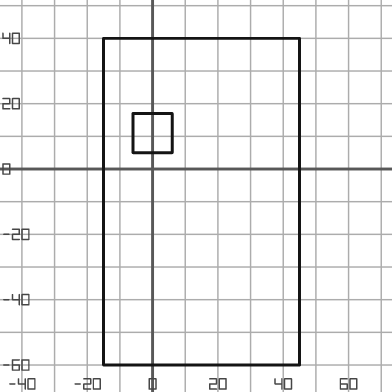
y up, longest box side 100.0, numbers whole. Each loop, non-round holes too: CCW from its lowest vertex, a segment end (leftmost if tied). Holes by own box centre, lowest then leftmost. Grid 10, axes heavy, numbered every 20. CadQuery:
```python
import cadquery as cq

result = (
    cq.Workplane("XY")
    .moveTo(-15.0, -60.0)
    .lineTo(45.0, -60.0)
    .lineTo(45.0, 40.0)
    .lineTo(-15.0, 40.0)
    .close()
    .moveTo(-6.0, 5.0)
    .lineTo(6.0, 5.0)
    .lineTo(6.0, 17.0)
    .lineTo(-6.0, 17.0)
    .close()
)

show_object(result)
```